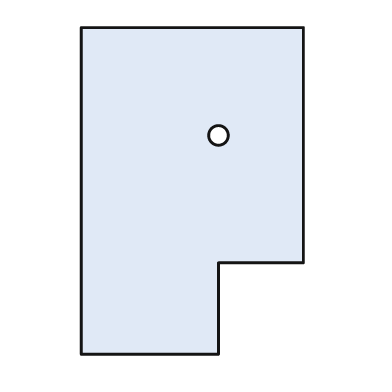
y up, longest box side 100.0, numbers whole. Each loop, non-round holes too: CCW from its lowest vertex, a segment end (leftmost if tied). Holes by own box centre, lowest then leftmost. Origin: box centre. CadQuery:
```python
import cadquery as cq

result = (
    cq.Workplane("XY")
    .moveTo(-34.0, -50.0)
    .lineTo(8.0, -50.0)
    .lineTo(8.0, -22.0)
    .lineTo(34.0, -22.0)
    .lineTo(34.0, 50.0)
    .lineTo(-34.0, 50.0)
    .close()
    .moveTo(8.0, 17.0)
    .circle(3.0)
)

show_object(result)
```